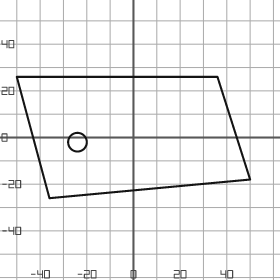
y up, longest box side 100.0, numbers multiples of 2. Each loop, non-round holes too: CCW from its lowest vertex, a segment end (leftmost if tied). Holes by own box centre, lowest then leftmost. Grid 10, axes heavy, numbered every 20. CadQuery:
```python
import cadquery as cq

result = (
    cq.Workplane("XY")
    .moveTo(-36.0, -26.0)
    .lineTo(50.0, -18.0)
    .lineTo(36.0, 26.0)
    .lineTo(-50.0, 26.0)
    .close()
    .moveTo(-24.0, -2.0)
    .circle(4.0)
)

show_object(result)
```